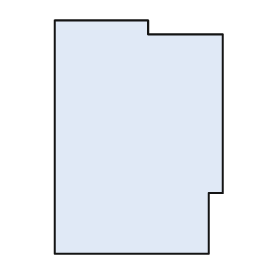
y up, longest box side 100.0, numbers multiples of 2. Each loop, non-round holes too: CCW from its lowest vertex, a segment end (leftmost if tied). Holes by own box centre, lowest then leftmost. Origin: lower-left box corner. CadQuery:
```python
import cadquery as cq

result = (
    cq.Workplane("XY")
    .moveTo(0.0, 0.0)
    .lineTo(66.0, 0.0)
    .lineTo(66.0, 26.0)
    .lineTo(72.0, 26.0)
    .lineTo(72.0, 94.0)
    .lineTo(40.0, 94.0)
    .lineTo(40.0, 100.0)
    .lineTo(0.0, 100.0)
    .close()
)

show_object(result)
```